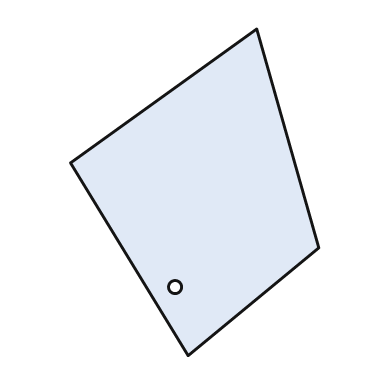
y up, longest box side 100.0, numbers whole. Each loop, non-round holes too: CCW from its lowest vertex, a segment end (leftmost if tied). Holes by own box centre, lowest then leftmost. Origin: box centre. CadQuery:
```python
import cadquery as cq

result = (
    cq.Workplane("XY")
    .moveTo(-2.0, -50.0)
    .lineTo(38.0, -17.0)
    .lineTo(19.0, 50.0)
    .lineTo(-38.0, 9.0)
    .close()
    .moveTo(-6.0, -29.0)
    .circle(2.0)
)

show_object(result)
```